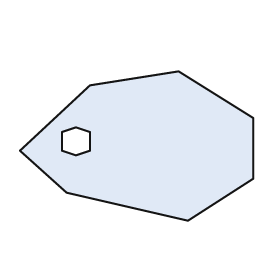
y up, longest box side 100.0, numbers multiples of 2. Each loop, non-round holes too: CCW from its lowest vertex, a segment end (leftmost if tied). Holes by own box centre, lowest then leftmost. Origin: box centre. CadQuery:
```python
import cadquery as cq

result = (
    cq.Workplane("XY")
    .moveTo(22.0, -32.0)
    .lineTo(50.0, -14.0)
    .lineTo(50.0, 12.0)
    .lineTo(18.0, 32.0)
    .lineTo(-20.0, 26.0)
    .lineTo(-50.0, -2.0)
    .lineTo(-30.0, -20.0)
    .close()
    .moveTo(-26.0, -4.0)
    .lineTo(-20.0, -2.0)
    .lineTo(-20.0, 6.0)
    .lineTo(-26.0, 8.0)
    .lineTo(-32.0, 6.0)
    .lineTo(-32.0, -2.0)
    .close()
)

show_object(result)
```